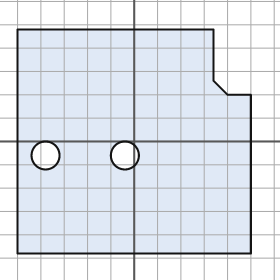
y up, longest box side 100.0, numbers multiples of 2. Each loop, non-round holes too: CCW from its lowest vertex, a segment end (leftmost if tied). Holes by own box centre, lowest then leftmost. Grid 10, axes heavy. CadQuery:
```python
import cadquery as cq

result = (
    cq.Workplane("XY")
    .moveTo(-50.0, -48.0)
    .lineTo(50.0, -48.0)
    .lineTo(50.0, 20.0)
    .lineTo(40.0, 20.0)
    .lineTo(34.0, 26.0)
    .lineTo(34.0, 48.0)
    .lineTo(-50.0, 48.0)
    .close()
    .moveTo(-38.0, -6.0)
    .circle(6.0)
    .moveTo(-4.0, -6.0)
    .circle(6.0)
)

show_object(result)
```